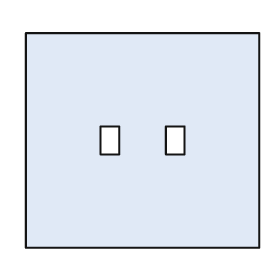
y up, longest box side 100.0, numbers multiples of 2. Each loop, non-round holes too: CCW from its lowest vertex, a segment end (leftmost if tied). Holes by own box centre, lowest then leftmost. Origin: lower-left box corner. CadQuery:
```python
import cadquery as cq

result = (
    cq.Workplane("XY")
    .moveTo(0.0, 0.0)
    .lineTo(100.0, 0.0)
    .lineTo(100.0, 92.0)
    .lineTo(0.0, 92.0)
    .close()
    .moveTo(32.0, 40.0)
    .lineTo(40.0, 40.0)
    .lineTo(40.0, 52.0)
    .lineTo(32.0, 52.0)
    .close()
    .moveTo(60.0, 40.0)
    .lineTo(68.0, 40.0)
    .lineTo(68.0, 52.0)
    .lineTo(60.0, 52.0)
    .close()
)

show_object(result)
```